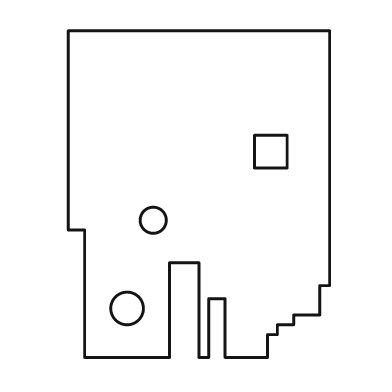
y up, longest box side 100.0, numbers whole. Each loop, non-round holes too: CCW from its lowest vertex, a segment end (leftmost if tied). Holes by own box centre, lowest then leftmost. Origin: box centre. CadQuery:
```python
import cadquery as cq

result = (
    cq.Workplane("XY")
    .moveTo(-35.0, -50.0)
    .lineTo(-9.0, -50.0)
    .lineTo(-9.0, -21.0)
    .lineTo(0.0, -21.0)
    .lineTo(0.0, -50.0)
    .lineTo(3.0, -50.0)
    .lineTo(3.0, -32.0)
    .lineTo(8.0, -32.0)
    .lineTo(8.0, -50.0)
    .lineTo(21.0, -50.0)
    .lineTo(21.0, -43.0)
    .lineTo(24.0, -43.0)
    .lineTo(24.0, -40.0)
    .lineTo(29.0, -40.0)
    .lineTo(29.0, -37.0)
    .lineTo(37.0, -37.0)
    .lineTo(37.0, -28.0)
    .lineTo(40.0, -28.0)
    .lineTo(40.0, 50.0)
    .lineTo(-40.0, 50.0)
    .lineTo(-40.0, -11.0)
    .lineTo(-35.0, -11.0)
    .close()
    .moveTo(-22.0, -35.0)
    .circle(5.0)
    .moveTo(-14.0, -8.0)
    .circle(4.0)
    .moveTo(17.0, 8.0)
    .lineTo(27.0, 8.0)
    .lineTo(27.0, 18.0)
    .lineTo(17.0, 18.0)
    .close()
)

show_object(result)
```